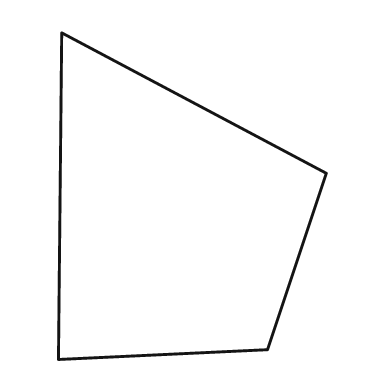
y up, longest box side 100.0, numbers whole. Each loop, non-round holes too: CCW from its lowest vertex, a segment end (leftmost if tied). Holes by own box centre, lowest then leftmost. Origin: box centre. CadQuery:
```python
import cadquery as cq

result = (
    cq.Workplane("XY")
    .moveTo(-41.0, -50.0)
    .lineTo(23.0, -47.0)
    .lineTo(41.0, 7.0)
    .lineTo(-40.0, 50.0)
    .close()
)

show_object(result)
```